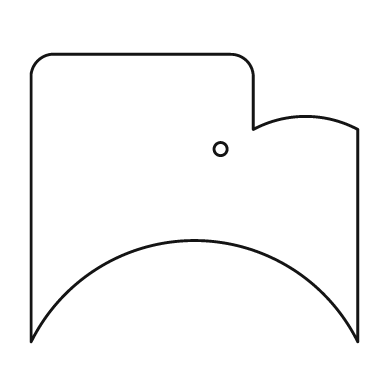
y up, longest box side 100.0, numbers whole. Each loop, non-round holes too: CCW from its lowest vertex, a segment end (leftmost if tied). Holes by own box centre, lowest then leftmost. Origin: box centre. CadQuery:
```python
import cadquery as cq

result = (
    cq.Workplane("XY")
    .moveTo(-50.0, -44.0)
    .threePointArc((0.0, -13.0), (50.0, -44.0))
    .lineTo(50.0, 21.0)
    .threePointArc((34.0, 25.0), (18.0, 21.0))
    .lineTo(18.0, 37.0)
    .threePointArc((16.0, 42.0), (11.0, 44.0))
    .lineTo(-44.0, 44.0)
    .threePointArc((-48.0, 42.0), (-50.0, 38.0))
    .close()
    .moveTo(8.0, 15.0)
    .circle(2.0)
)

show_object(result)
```